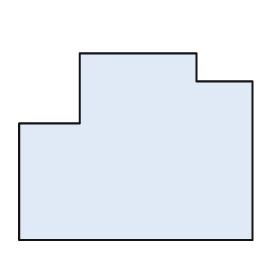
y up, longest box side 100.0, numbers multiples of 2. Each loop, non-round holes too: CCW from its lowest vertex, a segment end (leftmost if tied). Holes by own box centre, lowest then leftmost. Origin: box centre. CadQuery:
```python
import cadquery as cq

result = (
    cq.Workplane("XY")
    .moveTo(-50.0, -40.0)
    .lineTo(50.0, -40.0)
    .lineTo(50.0, 28.0)
    .lineTo(26.0, 28.0)
    .lineTo(26.0, 40.0)
    .lineTo(-24.0, 40.0)
    .lineTo(-24.0, 10.0)
    .lineTo(-50.0, 10.0)
    .close()
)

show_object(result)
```